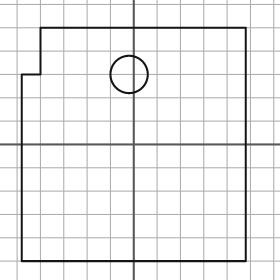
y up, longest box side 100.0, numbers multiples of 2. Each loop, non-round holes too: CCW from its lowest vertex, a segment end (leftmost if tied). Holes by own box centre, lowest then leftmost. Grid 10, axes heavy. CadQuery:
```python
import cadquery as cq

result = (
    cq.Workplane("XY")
    .moveTo(-48.0, -50.0)
    .lineTo(48.0, -50.0)
    .lineTo(48.0, 50.0)
    .lineTo(-40.0, 50.0)
    .lineTo(-40.0, 30.0)
    .lineTo(-48.0, 30.0)
    .close()
    .moveTo(-2.0, 30.0)
    .circle(8.0)
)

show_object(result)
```